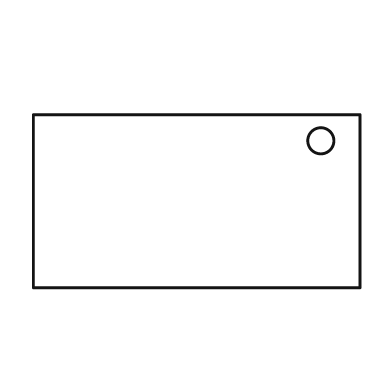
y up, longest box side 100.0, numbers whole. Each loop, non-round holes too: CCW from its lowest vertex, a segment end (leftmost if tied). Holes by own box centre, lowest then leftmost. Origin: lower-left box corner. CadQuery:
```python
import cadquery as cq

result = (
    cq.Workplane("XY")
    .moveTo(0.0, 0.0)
    .lineTo(100.0, 0.0)
    .lineTo(100.0, 53.0)
    .lineTo(0.0, 53.0)
    .close()
    .moveTo(88.0, 45.0)
    .circle(4.0)
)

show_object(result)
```